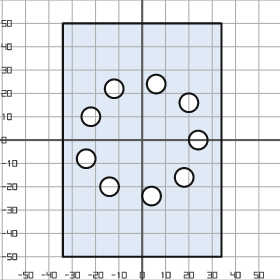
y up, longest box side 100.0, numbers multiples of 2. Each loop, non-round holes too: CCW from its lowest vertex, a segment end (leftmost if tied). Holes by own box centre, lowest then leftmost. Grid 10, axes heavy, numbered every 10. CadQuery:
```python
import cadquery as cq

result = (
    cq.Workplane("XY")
    .moveTo(-34.0, -50.0)
    .lineTo(34.0, -50.0)
    .lineTo(34.0, 50.0)
    .lineTo(-34.0, 50.0)
    .close()
    .moveTo(4.0, -24.0)
    .circle(4.0)
    .moveTo(-14.0, -20.0)
    .circle(4.0)
    .moveTo(18.0, -16.0)
    .circle(4.0)
    .moveTo(-24.0, -8.0)
    .circle(4.0)
    .moveTo(24.0, 0.0)
    .circle(4.0)
    .moveTo(-22.0, 10.0)
    .circle(4.0)
    .moveTo(20.0, 16.0)
    .circle(4.0)
    .moveTo(-12.0, 22.0)
    .circle(4.0)
    .moveTo(6.0, 24.0)
    .circle(4.0)
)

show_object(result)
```